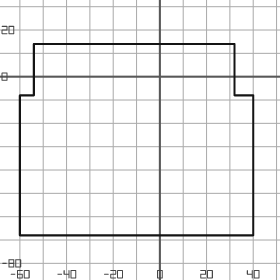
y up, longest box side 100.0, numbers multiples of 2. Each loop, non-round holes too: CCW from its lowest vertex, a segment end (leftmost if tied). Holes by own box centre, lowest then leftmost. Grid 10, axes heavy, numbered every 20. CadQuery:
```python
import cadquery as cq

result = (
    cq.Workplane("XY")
    .moveTo(-60.0, -68.0)
    .lineTo(40.0, -68.0)
    .lineTo(40.0, -8.0)
    .lineTo(32.0, -8.0)
    .lineTo(32.0, 14.0)
    .lineTo(-54.0, 14.0)
    .lineTo(-54.0, -8.0)
    .lineTo(-60.0, -8.0)
    .close()
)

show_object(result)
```